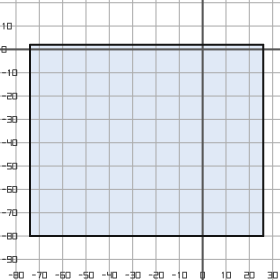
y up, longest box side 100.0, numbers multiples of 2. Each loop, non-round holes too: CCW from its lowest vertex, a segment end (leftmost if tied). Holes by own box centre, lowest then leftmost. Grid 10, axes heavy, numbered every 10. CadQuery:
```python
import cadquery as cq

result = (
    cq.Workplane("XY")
    .moveTo(-74.0, -80.0)
    .lineTo(26.0, -80.0)
    .lineTo(26.0, 2.0)
    .lineTo(-74.0, 2.0)
    .close()
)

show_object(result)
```